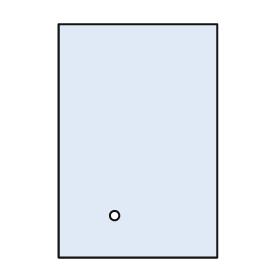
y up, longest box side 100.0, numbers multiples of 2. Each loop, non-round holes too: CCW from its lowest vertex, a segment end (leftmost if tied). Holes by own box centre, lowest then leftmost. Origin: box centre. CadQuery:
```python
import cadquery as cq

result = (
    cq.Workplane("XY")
    .moveTo(-34.0, -50.0)
    .lineTo(34.0, -50.0)
    .lineTo(34.0, 50.0)
    .lineTo(-34.0, 50.0)
    .close()
    .moveTo(-10.0, -32.0)
    .circle(2.0)
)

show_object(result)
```